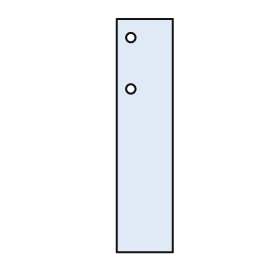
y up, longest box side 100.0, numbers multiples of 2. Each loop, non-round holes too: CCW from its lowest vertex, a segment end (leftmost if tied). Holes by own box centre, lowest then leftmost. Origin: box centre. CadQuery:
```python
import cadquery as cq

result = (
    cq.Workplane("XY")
    .moveTo(-12.0, -50.0)
    .lineTo(12.0, -50.0)
    .lineTo(12.0, 50.0)
    .lineTo(-12.0, 50.0)
    .close()
    .moveTo(-6.0, 20.0)
    .circle(2.0)
    .moveTo(-6.0, 42.0)
    .circle(2.0)
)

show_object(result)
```